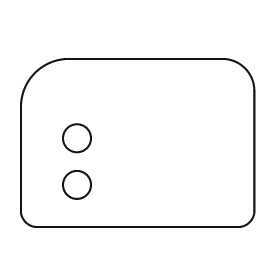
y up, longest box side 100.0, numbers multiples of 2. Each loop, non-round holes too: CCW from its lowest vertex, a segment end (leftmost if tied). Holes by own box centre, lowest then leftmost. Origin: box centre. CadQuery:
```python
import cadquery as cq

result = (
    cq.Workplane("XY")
    .moveTo(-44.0, -36.0)
    .lineTo(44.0, -36.0)
    .threePointArc((48.0, -34.0), (50.0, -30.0))
    .lineTo(50.0, 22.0)
    .threePointArc((46.0, 32.0), (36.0, 36.0))
    .lineTo(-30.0, 36.0)
    .threePointArc((-44.0, 30.0), (-50.0, 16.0))
    .lineTo(-50.0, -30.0)
    .threePointArc((-48.0, -34.0), (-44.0, -36.0))
    .close()
    .moveTo(-26.0, -18.0)
    .circle(6.0)
    .moveTo(-26.0, 2.0)
    .circle(6.0)
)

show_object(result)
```